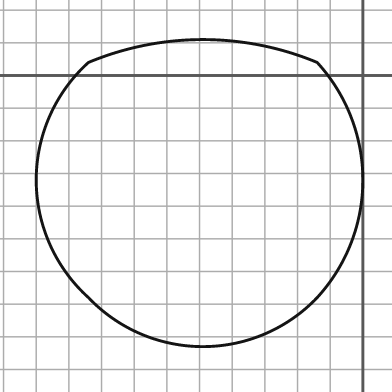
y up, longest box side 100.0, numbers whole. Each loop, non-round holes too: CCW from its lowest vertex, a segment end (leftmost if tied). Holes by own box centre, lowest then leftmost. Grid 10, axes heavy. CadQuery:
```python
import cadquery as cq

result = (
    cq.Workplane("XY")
    .moveTo(-84.0, -68.0)
    .threePointArc((-49.0, -83.0), (-14.0, -68.0))
    .threePointArc((0.0, -32.0), (-14.0, 4.0))
    .threePointArc((-49.0, 11.0), (-84.0, 4.0))
    .threePointArc((-100.0, -32.0), (-84.0, -68.0))
    .close()
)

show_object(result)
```